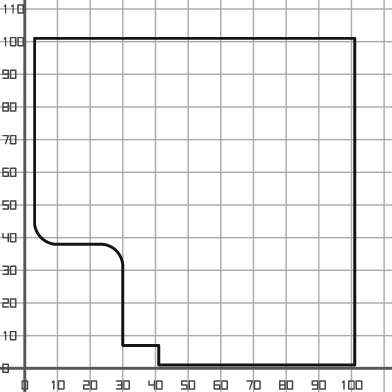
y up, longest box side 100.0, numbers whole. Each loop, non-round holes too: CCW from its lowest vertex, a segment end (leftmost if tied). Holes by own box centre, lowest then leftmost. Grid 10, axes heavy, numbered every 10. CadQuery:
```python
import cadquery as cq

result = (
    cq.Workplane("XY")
    .moveTo(41.0, 1.0)
    .lineTo(101.0, 1.0)
    .lineTo(101.0, 101.0)
    .lineTo(3.0, 101.0)
    .lineTo(3.0, 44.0)
    .threePointArc((5.0, 40.0), (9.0, 38.0))
    .lineTo(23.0, 38.0)
    .threePointArc((28.0, 36.0), (30.0, 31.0))
    .lineTo(30.0, 7.0)
    .lineTo(41.0, 7.0)
    .close()
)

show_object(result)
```